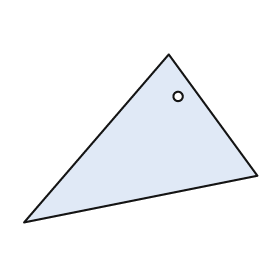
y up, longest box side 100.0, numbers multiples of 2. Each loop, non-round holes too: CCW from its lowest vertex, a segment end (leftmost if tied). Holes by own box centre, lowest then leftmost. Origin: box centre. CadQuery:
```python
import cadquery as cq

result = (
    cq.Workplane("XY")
    .moveTo(-50.0, -36.0)
    .lineTo(50.0, -16.0)
    .lineTo(12.0, 36.0)
    .close()
    .moveTo(16.0, 18.0)
    .circle(2.0)
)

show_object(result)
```